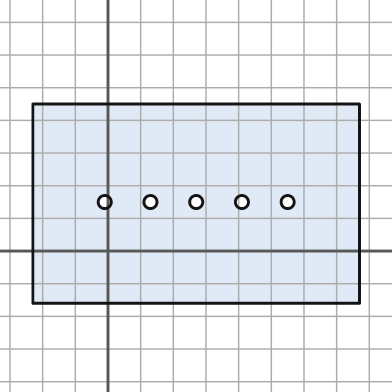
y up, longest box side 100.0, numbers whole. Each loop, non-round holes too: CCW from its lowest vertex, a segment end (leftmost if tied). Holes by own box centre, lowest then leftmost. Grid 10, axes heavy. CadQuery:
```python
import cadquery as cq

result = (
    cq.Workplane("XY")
    .moveTo(-23.0, -16.0)
    .lineTo(77.0, -16.0)
    .lineTo(77.0, 45.0)
    .lineTo(-23.0, 45.0)
    .close()
    .moveTo(-1.0, 15.0)
    .circle(2.0)
    .moveTo(13.0, 15.0)
    .circle(2.0)
    .moveTo(27.0, 15.0)
    .circle(2.0)
    .moveTo(41.0, 15.0)
    .circle(2.0)
    .moveTo(55.0, 15.0)
    .circle(2.0)
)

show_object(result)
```